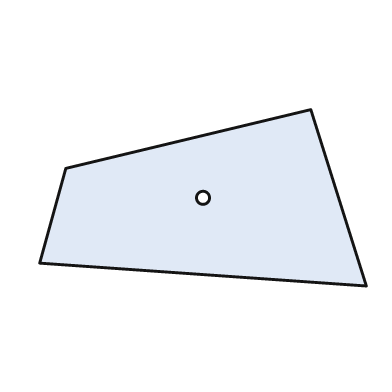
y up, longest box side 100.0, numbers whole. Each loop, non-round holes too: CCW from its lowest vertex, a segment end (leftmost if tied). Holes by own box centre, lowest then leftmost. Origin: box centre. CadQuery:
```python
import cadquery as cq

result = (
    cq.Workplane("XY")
    .moveTo(50.0, -27.0)
    .lineTo(33.0, 27.0)
    .lineTo(-42.0, 9.0)
    .lineTo(-50.0, -20.0)
    .close()
    .moveTo(0.0, 0.0)
    .circle(2.0)
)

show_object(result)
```